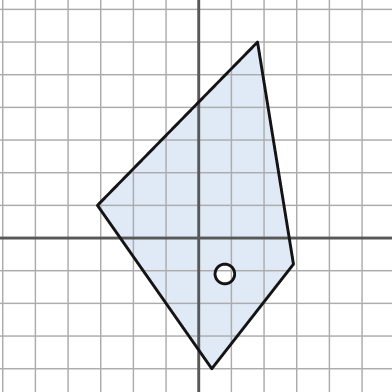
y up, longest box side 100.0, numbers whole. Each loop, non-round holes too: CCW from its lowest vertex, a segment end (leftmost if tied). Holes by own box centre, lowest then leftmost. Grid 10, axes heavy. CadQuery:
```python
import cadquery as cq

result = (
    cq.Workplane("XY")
    .moveTo(4.0, -40.0)
    .lineTo(29.0, -8.0)
    .lineTo(18.0, 60.0)
    .lineTo(-31.0, 10.0)
    .close()
    .moveTo(8.0, -11.0)
    .circle(3.0)
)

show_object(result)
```